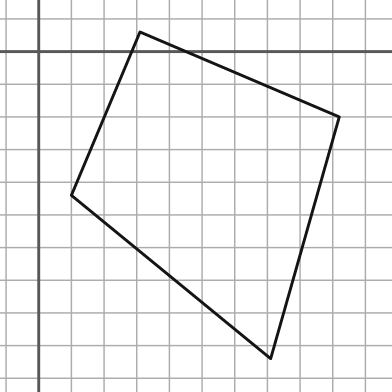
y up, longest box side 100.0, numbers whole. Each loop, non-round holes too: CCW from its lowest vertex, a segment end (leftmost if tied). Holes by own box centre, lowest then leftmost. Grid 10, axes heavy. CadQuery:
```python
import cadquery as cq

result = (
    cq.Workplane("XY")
    .moveTo(71.0, -94.0)
    .lineTo(92.0, -20.0)
    .lineTo(31.0, 6.0)
    .lineTo(10.0, -44.0)
    .close()
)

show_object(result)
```